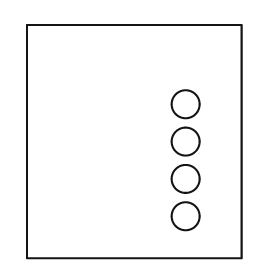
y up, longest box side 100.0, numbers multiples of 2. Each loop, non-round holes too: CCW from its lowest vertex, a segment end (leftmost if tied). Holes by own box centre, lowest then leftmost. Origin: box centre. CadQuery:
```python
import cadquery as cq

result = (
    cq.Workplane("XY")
    .moveTo(-46.0, -50.0)
    .lineTo(46.0, -50.0)
    .lineTo(46.0, 50.0)
    .lineTo(-46.0, 50.0)
    .close()
    .moveTo(22.0, -32.0)
    .circle(6.0)
    .moveTo(22.0, -16.0)
    .circle(6.0)
    .moveTo(22.0, 0.0)
    .circle(6.0)
    .moveTo(22.0, 16.0)
    .circle(6.0)
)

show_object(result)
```